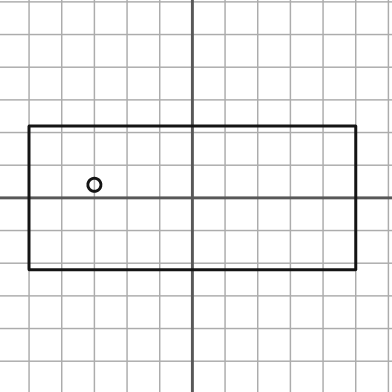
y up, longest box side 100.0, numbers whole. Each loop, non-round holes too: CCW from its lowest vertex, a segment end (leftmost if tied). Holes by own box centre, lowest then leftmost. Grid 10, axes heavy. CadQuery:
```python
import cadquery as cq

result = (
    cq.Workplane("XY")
    .moveTo(-50.0, -22.0)
    .lineTo(50.0, -22.0)
    .lineTo(50.0, 22.0)
    .lineTo(-50.0, 22.0)
    .close()
    .moveTo(-30.0, 4.0)
    .circle(2.0)
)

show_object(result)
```